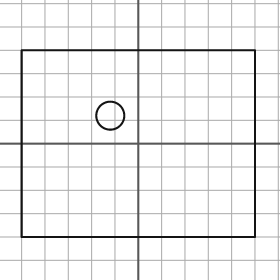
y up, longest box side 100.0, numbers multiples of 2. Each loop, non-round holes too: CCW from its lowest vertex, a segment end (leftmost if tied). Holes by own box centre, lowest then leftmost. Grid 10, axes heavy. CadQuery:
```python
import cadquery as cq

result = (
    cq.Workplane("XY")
    .moveTo(-50.0, -40.0)
    .lineTo(50.0, -40.0)
    .lineTo(50.0, 40.0)
    .lineTo(-50.0, 40.0)
    .close()
    .moveTo(-12.0, 12.0)
    .circle(6.0)
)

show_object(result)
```